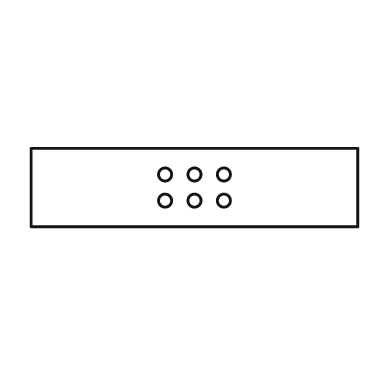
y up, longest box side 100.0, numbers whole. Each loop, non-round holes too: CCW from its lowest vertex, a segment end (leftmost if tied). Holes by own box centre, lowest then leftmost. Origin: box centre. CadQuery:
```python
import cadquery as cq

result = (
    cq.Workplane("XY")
    .moveTo(-50.0, -12.0)
    .lineTo(50.0, -12.0)
    .lineTo(50.0, 12.0)
    .lineTo(-50.0, 12.0)
    .close()
    .moveTo(-9.0, -4.0)
    .circle(2.0)
    .moveTo(0.0, -4.0)
    .circle(2.0)
    .moveTo(9.0, -4.0)
    .circle(2.0)
    .moveTo(-9.0, 4.0)
    .circle(2.0)
    .moveTo(0.0, 4.0)
    .circle(2.0)
    .moveTo(9.0, 4.0)
    .circle(2.0)
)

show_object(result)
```